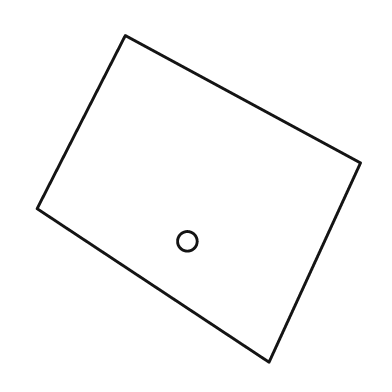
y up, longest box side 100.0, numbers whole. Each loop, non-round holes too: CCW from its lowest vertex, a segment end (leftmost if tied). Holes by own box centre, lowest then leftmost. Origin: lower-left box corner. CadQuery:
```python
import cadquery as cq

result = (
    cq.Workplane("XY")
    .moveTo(71.0, 0.0)
    .lineTo(99.0, 61.0)
    .lineTo(27.0, 100.0)
    .lineTo(0.0, 47.0)
    .close()
    .moveTo(46.0, 37.0)
    .circle(3.0)
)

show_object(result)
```